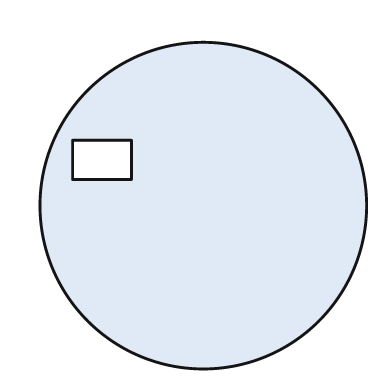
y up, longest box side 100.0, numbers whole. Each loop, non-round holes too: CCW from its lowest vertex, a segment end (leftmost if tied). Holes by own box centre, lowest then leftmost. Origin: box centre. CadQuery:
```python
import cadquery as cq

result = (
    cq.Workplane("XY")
    .moveTo(0.0, 0.0)
    .circle(50.0)
    .moveTo(-40.0, 8.0)
    .lineTo(-22.0, 8.0)
    .lineTo(-22.0, 20.0)
    .lineTo(-40.0, 20.0)
    .close()
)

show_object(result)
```